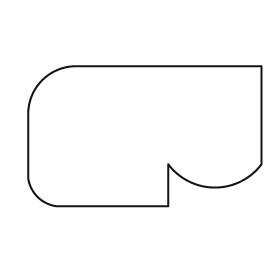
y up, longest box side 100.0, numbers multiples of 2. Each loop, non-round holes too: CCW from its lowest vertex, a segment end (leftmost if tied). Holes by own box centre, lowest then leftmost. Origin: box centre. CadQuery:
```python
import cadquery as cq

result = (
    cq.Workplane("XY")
    .moveTo(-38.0, -30.0)
    .lineTo(10.0, -30.0)
    .lineTo(10.0, -12.0)
    .threePointArc((30.0, -22.0), (50.0, -12.0))
    .lineTo(50.0, 30.0)
    .lineTo(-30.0, 30.0)
    .threePointArc((-44.0, 24.0), (-50.0, 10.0))
    .lineTo(-50.0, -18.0)
    .threePointArc((-46.0, -26.0), (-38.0, -30.0))
    .close()
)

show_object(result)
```